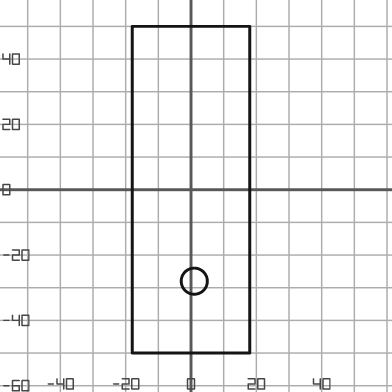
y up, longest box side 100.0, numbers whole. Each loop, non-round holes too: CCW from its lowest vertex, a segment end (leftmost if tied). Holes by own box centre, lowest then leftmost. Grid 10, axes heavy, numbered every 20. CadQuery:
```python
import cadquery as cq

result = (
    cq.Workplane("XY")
    .moveTo(-18.0, -50.0)
    .lineTo(18.0, -50.0)
    .lineTo(18.0, 50.0)
    .lineTo(-18.0, 50.0)
    .close()
    .moveTo(1.0, -28.0)
    .circle(4.0)
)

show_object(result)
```